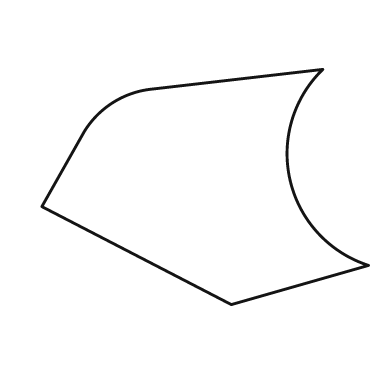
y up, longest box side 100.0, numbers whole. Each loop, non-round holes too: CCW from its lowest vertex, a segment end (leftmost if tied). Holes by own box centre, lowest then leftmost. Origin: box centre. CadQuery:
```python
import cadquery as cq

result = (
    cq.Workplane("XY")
    .moveTo(8.0, -36.0)
    .lineTo(50.0, -24.0)
    .threePointArc((26.0, 2.0), (36.0, 36.0))
    .lineTo(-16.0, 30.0)
    .threePointArc((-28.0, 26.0), (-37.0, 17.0))
    .lineTo(-50.0, -6.0)
    .close()
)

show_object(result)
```